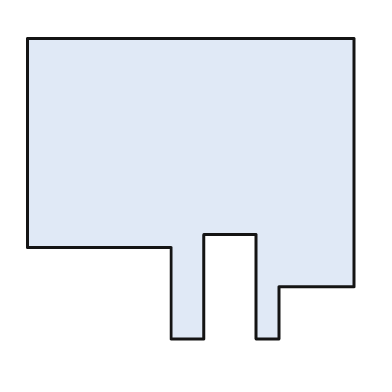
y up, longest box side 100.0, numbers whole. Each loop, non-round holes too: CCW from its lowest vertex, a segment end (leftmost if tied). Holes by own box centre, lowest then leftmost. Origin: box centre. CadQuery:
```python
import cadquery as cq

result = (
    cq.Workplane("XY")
    .moveTo(-6.0, -46.0)
    .lineTo(4.0, -46.0)
    .lineTo(4.0, -14.0)
    .lineTo(20.0, -14.0)
    .lineTo(20.0, -46.0)
    .lineTo(27.0, -46.0)
    .lineTo(27.0, -30.0)
    .lineTo(50.0, -30.0)
    .lineTo(50.0, 46.0)
    .lineTo(-50.0, 46.0)
    .lineTo(-50.0, -18.0)
    .lineTo(-6.0, -18.0)
    .close()
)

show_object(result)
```